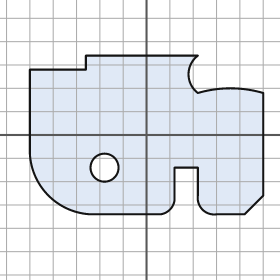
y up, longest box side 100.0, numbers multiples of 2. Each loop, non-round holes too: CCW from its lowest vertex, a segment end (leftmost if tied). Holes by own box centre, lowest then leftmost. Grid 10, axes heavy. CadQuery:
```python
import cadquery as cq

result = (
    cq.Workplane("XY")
    .moveTo(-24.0, -34.0)
    .lineTo(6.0, -34.0)
    .threePointArc((10.0, -32.0), (12.0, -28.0))
    .lineTo(12.0, -14.0)
    .lineTo(22.0, -14.0)
    .lineTo(22.0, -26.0)
    .threePointArc((24.0, -32.0), (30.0, -34.0))
    .lineTo(42.0, -34.0)
    .lineTo(50.0, -26.0)
    .lineTo(50.0, 18.0)
    .threePointArc((36.0, 20.0), (22.0, 18.0))
    .threePointArc((18.0, 26.0), (22.0, 34.0))
    .lineTo(-26.0, 34.0)
    .lineTo(-26.0, 28.0)
    .lineTo(-50.0, 28.0)
    .lineTo(-50.0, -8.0)
    .threePointArc((-42.0, -26.0), (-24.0, -34.0))
    .close()
    .moveTo(-18.0, -14.0)
    .circle(6.0)
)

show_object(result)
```